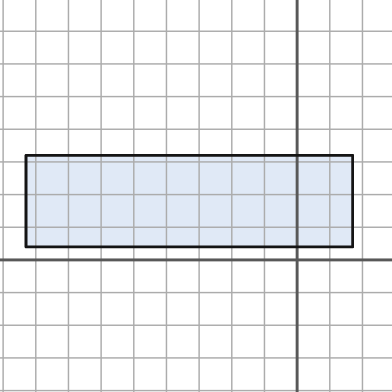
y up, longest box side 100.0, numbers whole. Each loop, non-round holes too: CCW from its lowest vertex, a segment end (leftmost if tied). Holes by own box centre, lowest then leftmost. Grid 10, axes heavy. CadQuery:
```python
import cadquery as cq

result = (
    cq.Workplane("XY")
    .moveTo(-83.0, 4.0)
    .lineTo(17.0, 4.0)
    .lineTo(17.0, 32.0)
    .lineTo(-83.0, 32.0)
    .close()
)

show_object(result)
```